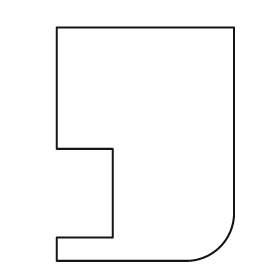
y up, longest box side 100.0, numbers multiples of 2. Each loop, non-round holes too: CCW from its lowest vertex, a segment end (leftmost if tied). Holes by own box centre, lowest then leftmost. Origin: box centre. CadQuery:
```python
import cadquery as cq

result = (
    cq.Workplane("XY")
    .moveTo(-38.0, -50.0)
    .lineTo(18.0, -50.0)
    .threePointArc((32.0, -44.0), (38.0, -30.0))
    .lineTo(38.0, 50.0)
    .lineTo(-38.0, 50.0)
    .lineTo(-38.0, -2.0)
    .lineTo(-14.0, -2.0)
    .lineTo(-14.0, -40.0)
    .lineTo(-38.0, -40.0)
    .close()
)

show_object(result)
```